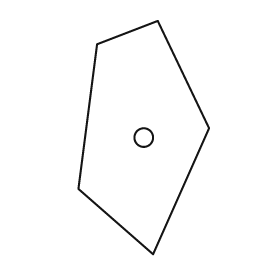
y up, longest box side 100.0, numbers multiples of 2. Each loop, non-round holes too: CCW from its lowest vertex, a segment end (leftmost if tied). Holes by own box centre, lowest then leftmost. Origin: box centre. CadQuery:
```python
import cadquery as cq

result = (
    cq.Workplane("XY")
    .moveTo(4.0, -50.0)
    .lineTo(28.0, 4.0)
    .lineTo(6.0, 50.0)
    .lineTo(-20.0, 40.0)
    .lineTo(-28.0, -22.0)
    .close()
    .moveTo(0.0, 0.0)
    .circle(4.0)
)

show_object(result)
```